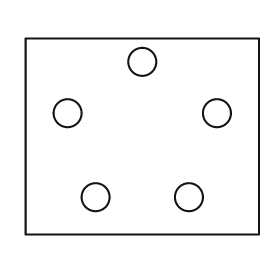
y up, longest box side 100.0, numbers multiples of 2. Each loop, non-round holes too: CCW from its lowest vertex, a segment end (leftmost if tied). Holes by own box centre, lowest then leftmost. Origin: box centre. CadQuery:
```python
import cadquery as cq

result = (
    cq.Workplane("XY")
    .moveTo(-50.0, -42.0)
    .lineTo(50.0, -42.0)
    .lineTo(50.0, 42.0)
    .lineTo(-50.0, 42.0)
    .close()
    .moveTo(-20.0, -26.0)
    .circle(6.0)
    .moveTo(20.0, -26.0)
    .circle(6.0)
    .moveTo(-32.0, 10.0)
    .circle(6.0)
    .moveTo(32.0, 10.0)
    .circle(6.0)
    .moveTo(0.0, 32.0)
    .circle(6.0)
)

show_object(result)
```